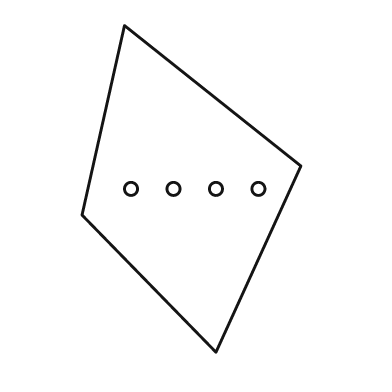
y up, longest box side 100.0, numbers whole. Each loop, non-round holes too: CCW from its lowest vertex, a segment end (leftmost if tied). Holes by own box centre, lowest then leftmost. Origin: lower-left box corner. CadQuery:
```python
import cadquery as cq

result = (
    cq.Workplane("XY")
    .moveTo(41.0, 0.0)
    .lineTo(67.0, 57.0)
    .lineTo(13.0, 100.0)
    .lineTo(0.0, 42.0)
    .close()
    .moveTo(15.0, 50.0)
    .circle(2.0)
    .moveTo(28.0, 50.0)
    .circle(2.0)
    .moveTo(41.0, 50.0)
    .circle(2.0)
    .moveTo(54.0, 50.0)
    .circle(2.0)
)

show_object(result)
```